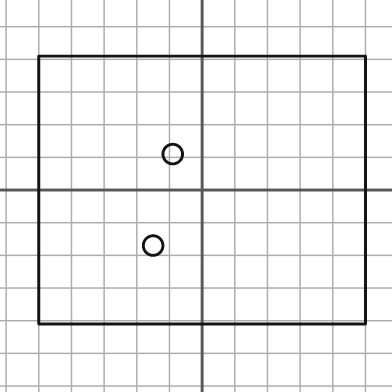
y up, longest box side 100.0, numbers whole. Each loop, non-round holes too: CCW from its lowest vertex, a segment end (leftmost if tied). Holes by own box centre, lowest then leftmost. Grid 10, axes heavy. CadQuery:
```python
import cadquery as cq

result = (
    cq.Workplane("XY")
    .moveTo(-50.0, -41.0)
    .lineTo(50.0, -41.0)
    .lineTo(50.0, 41.0)
    .lineTo(-50.0, 41.0)
    .close()
    .moveTo(-15.0, -17.0)
    .circle(3.0)
    .moveTo(-9.0, 11.0)
    .circle(3.0)
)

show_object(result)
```